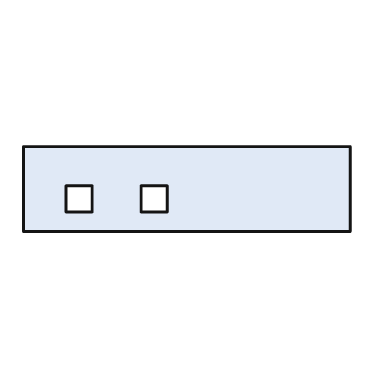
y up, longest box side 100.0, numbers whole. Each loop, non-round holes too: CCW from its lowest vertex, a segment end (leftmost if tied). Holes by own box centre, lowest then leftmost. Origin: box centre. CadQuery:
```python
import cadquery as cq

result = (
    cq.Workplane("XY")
    .moveTo(-50.0, -13.0)
    .lineTo(50.0, -13.0)
    .lineTo(50.0, 13.0)
    .lineTo(-50.0, 13.0)
    .close()
    .moveTo(-37.0, -7.0)
    .lineTo(-29.0, -7.0)
    .lineTo(-29.0, 1.0)
    .lineTo(-37.0, 1.0)
    .close()
    .moveTo(-14.0, -7.0)
    .lineTo(-6.0, -7.0)
    .lineTo(-6.0, 1.0)
    .lineTo(-14.0, 1.0)
    .close()
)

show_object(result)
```